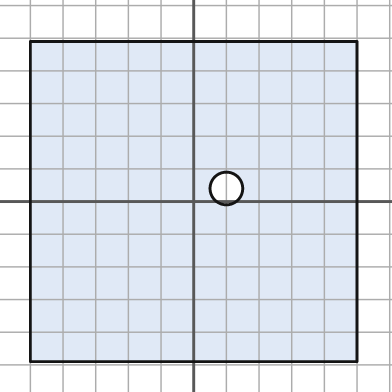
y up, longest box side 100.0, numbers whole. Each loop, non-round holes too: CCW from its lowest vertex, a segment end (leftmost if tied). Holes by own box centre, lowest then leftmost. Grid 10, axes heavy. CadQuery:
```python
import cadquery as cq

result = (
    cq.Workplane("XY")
    .moveTo(-50.0, -49.0)
    .lineTo(50.0, -49.0)
    .lineTo(50.0, 49.0)
    .lineTo(-50.0, 49.0)
    .close()
    .moveTo(10.0, 4.0)
    .circle(5.0)
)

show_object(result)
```